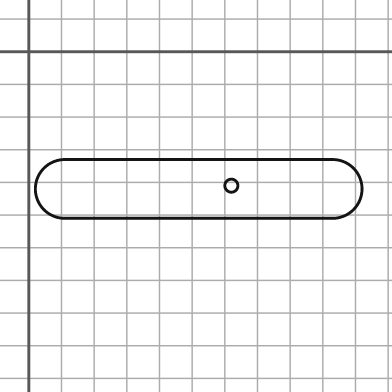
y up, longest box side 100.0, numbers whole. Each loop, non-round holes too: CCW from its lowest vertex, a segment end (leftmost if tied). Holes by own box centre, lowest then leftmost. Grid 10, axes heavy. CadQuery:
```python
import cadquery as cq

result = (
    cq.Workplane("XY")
    .moveTo(11.0, -51.0)
    .lineTo(93.0, -51.0)
    .threePointArc((102.0, -42.0), (93.0, -33.0))
    .lineTo(11.0, -33.0)
    .threePointArc((2.0, -42.0), (11.0, -51.0))
    .close()
    .moveTo(62.0, -41.0)
    .circle(2.0)
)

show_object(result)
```